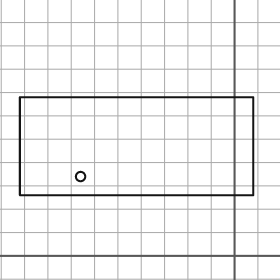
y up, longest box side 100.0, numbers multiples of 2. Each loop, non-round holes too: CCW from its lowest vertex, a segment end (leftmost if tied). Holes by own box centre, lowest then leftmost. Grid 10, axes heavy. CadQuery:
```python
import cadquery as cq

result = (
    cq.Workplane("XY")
    .moveTo(-92.0, 26.0)
    .lineTo(8.0, 26.0)
    .lineTo(8.0, 68.0)
    .lineTo(-92.0, 68.0)
    .close()
    .moveTo(-66.0, 34.0)
    .circle(2.0)
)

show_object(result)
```